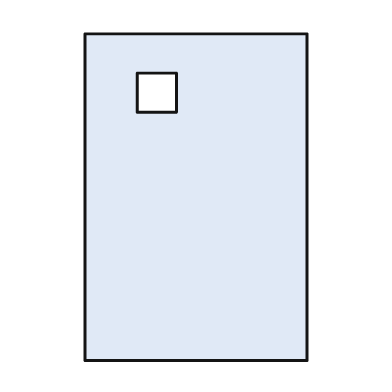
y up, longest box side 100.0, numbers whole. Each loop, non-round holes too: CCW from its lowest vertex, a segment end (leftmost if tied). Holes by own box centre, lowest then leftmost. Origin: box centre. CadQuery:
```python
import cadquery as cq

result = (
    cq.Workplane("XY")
    .moveTo(-34.0, -50.0)
    .lineTo(34.0, -50.0)
    .lineTo(34.0, 50.0)
    .lineTo(-34.0, 50.0)
    .close()
    .moveTo(-18.0, 26.0)
    .lineTo(-6.0, 26.0)
    .lineTo(-6.0, 38.0)
    .lineTo(-18.0, 38.0)
    .close()
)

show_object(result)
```